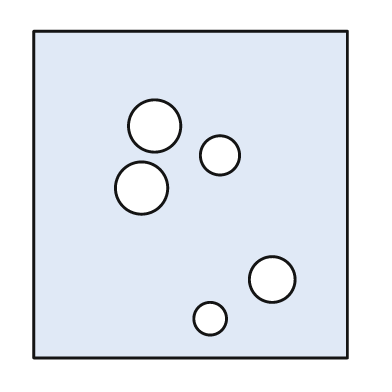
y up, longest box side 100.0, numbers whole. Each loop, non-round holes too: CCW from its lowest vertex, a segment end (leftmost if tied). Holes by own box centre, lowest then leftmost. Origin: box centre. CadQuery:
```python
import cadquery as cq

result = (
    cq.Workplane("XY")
    .moveTo(-48.0, -50.0)
    .lineTo(48.0, -50.0)
    .lineTo(48.0, 50.0)
    .lineTo(-48.0, 50.0)
    .close()
    .moveTo(6.0, -38.0)
    .circle(5.0)
    .moveTo(25.0, -26.0)
    .circle(7.0)
    .moveTo(-15.0, 2.0)
    .circle(8.0)
    .moveTo(9.0, 12.0)
    .circle(6.0)
    .moveTo(-11.0, 21.0)
    .circle(8.0)
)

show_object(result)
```